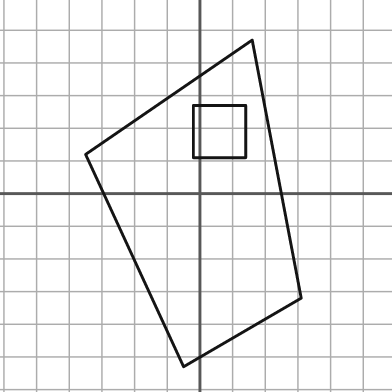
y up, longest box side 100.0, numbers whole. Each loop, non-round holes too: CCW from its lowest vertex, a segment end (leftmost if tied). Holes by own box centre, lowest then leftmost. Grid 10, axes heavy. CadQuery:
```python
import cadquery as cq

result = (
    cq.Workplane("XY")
    .moveTo(-5.0, -53.0)
    .lineTo(31.0, -32.0)
    .lineTo(16.0, 47.0)
    .lineTo(-35.0, 12.0)
    .close()
    .moveTo(-2.0, 11.0)
    .lineTo(14.0, 11.0)
    .lineTo(14.0, 27.0)
    .lineTo(-2.0, 27.0)
    .close()
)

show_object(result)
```